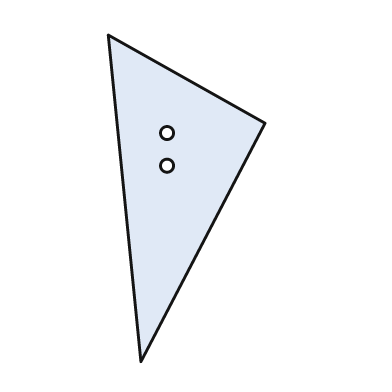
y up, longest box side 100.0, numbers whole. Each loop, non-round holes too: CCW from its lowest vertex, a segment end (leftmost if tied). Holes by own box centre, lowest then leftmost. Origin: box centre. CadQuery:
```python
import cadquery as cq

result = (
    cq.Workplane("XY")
    .moveTo(-14.0, -50.0)
    .lineTo(24.0, 23.0)
    .lineTo(-24.0, 50.0)
    .close()
    .moveTo(-6.0, 10.0)
    .circle(2.0)
    .moveTo(-6.0, 20.0)
    .circle(2.0)
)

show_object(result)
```